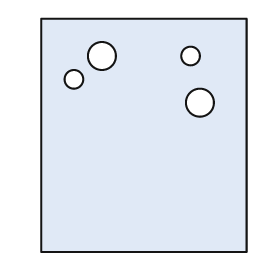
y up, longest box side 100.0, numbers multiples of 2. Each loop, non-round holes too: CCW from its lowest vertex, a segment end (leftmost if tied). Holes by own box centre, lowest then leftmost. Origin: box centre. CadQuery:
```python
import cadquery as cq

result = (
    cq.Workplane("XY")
    .moveTo(-44.0, -50.0)
    .lineTo(44.0, -50.0)
    .lineTo(44.0, 50.0)
    .lineTo(-44.0, 50.0)
    .close()
    .moveTo(24.0, 14.0)
    .circle(6.0)
    .moveTo(-30.0, 24.0)
    .circle(4.0)
    .moveTo(-18.0, 34.0)
    .circle(6.0)
    .moveTo(20.0, 34.0)
    .circle(4.0)
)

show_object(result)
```